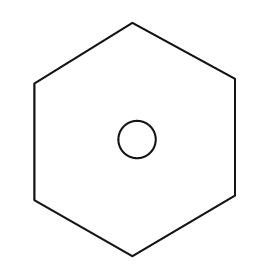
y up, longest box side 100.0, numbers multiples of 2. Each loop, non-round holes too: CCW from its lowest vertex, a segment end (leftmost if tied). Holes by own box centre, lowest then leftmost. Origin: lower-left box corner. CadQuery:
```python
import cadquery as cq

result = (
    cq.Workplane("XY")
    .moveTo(42.0, 0.0)
    .lineTo(86.0, 26.0)
    .lineTo(86.0, 76.0)
    .lineTo(42.0, 100.0)
    .lineTo(0.0, 74.0)
    .lineTo(0.0, 24.0)
    .close()
    .moveTo(44.0, 50.0)
    .circle(8.0)
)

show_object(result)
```